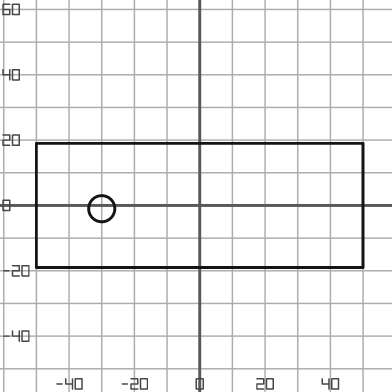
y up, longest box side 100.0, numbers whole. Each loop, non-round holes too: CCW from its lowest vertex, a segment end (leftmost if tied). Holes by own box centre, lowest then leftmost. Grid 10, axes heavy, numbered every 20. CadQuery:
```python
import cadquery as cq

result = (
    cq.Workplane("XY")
    .moveTo(-50.0, -19.0)
    .lineTo(50.0, -19.0)
    .lineTo(50.0, 19.0)
    .lineTo(-50.0, 19.0)
    .close()
    .moveTo(-30.0, -1.0)
    .circle(4.0)
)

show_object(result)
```